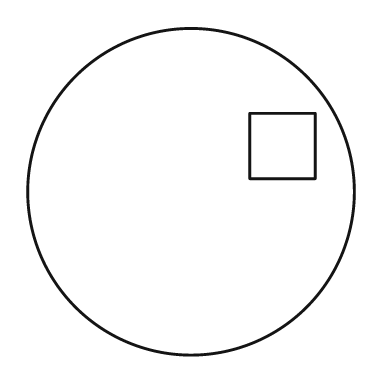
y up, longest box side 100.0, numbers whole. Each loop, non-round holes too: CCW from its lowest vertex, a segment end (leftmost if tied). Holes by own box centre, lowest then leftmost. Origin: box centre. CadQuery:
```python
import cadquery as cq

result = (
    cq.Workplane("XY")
    .moveTo(0.0, 0.0)
    .circle(50.0)
    .moveTo(18.0, 4.0)
    .lineTo(38.0, 4.0)
    .lineTo(38.0, 24.0)
    .lineTo(18.0, 24.0)
    .close()
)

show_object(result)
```